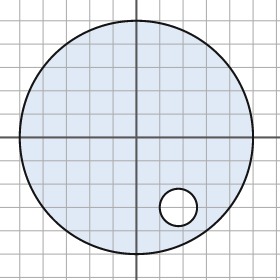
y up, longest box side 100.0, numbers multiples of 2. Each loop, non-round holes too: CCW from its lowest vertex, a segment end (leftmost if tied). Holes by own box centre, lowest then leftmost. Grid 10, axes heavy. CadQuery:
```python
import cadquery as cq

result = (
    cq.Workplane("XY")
    .moveTo(0.0, 0.0)
    .circle(50.0)
    .moveTo(18.0, -30.0)
    .circle(8.0)
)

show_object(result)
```